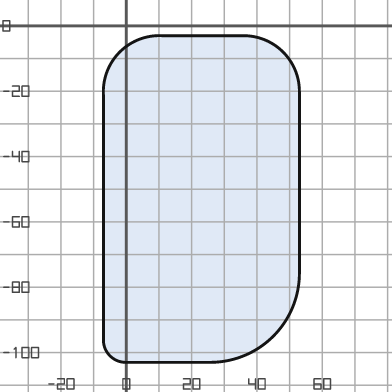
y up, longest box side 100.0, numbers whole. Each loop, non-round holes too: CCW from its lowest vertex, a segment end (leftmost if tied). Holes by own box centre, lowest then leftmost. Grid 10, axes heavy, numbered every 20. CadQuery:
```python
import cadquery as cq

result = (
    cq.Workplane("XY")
    .moveTo(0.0, -103.0)
    .lineTo(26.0, -103.0)
    .threePointArc((45.0, -95.0), (53.0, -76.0))
    .lineTo(53.0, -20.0)
    .threePointArc((48.0, -8.0), (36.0, -3.0))
    .lineTo(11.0, -3.0)
    .threePointArc((-2.0, -8.0), (-7.0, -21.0))
    .lineTo(-7.0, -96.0)
    .threePointArc((-5.0, -101.0), (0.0, -103.0))
    .close()
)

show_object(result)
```